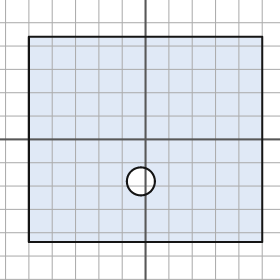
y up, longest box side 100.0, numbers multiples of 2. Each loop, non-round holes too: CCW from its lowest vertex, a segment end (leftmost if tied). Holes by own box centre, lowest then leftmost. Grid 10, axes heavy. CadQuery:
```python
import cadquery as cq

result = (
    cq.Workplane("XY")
    .moveTo(-50.0, -44.0)
    .lineTo(50.0, -44.0)
    .lineTo(50.0, 44.0)
    .lineTo(-50.0, 44.0)
    .close()
    .moveTo(-2.0, -18.0)
    .circle(6.0)
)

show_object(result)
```